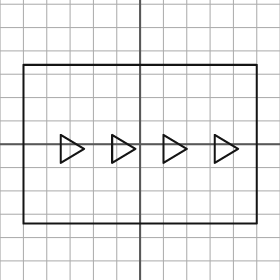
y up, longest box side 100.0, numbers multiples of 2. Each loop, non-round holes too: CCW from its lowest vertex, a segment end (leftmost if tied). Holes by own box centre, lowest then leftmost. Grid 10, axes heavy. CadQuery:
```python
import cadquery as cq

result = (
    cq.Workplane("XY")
    .moveTo(-50.0, -34.0)
    .lineTo(50.0, -34.0)
    .lineTo(50.0, 34.0)
    .lineTo(-50.0, 34.0)
    .close()
    .moveTo(-34.0, -8.0)
    .lineTo(-24.0, -2.0)
    .lineTo(-34.0, 4.0)
    .close()
    .moveTo(-12.0, -8.0)
    .lineTo(-2.0, -2.0)
    .lineTo(-12.0, 4.0)
    .close()
    .moveTo(10.0, -8.0)
    .lineTo(20.0, -2.0)
    .lineTo(10.0, 4.0)
    .close()
    .moveTo(32.0, -8.0)
    .lineTo(42.0, -2.0)
    .lineTo(32.0, 4.0)
    .close()
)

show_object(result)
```